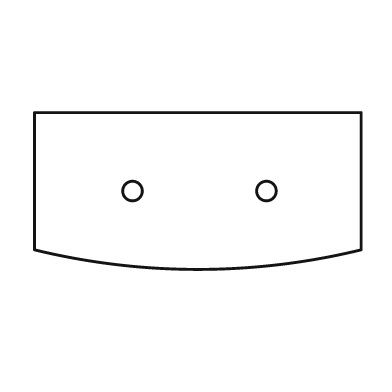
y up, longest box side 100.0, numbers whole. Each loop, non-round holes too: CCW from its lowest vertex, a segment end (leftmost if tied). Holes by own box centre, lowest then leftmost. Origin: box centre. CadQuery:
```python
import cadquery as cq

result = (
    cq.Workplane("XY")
    .moveTo(-50.0, -18.0)
    .threePointArc((0.0, -24.0), (50.0, -18.0))
    .lineTo(50.0, 24.0)
    .lineTo(-50.0, 24.0)
    .close()
    .moveTo(-20.0, 0.0)
    .circle(3.0)
    .moveTo(21.0, 0.0)
    .circle(3.0)
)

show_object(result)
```